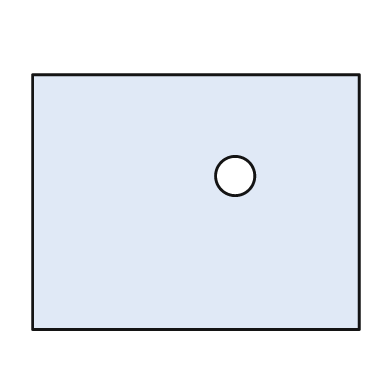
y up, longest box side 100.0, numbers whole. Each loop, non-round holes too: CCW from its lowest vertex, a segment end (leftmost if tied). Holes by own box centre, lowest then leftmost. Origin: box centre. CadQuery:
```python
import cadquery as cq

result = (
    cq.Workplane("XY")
    .moveTo(-50.0, -39.0)
    .lineTo(50.0, -39.0)
    .lineTo(50.0, 39.0)
    .lineTo(-50.0, 39.0)
    .close()
    .moveTo(12.0, 8.0)
    .circle(6.0)
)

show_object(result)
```